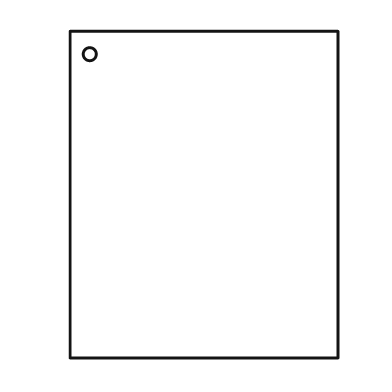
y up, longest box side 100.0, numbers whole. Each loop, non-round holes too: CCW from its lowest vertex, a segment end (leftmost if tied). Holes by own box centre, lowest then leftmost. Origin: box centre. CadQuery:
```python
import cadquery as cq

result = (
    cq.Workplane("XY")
    .moveTo(-41.0, -50.0)
    .lineTo(41.0, -50.0)
    .lineTo(41.0, 50.0)
    .lineTo(-41.0, 50.0)
    .close()
    .moveTo(-35.0, 43.0)
    .circle(2.0)
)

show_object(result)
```